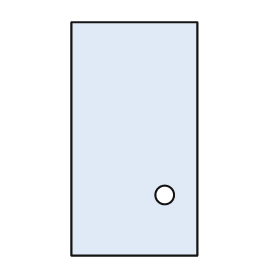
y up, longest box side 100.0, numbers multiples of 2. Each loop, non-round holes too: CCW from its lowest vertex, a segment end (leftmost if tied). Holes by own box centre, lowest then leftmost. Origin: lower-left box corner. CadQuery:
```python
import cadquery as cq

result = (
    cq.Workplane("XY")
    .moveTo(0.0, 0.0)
    .lineTo(54.0, 0.0)
    .lineTo(54.0, 100.0)
    .lineTo(0.0, 100.0)
    .close()
    .moveTo(40.0, 26.0)
    .circle(4.0)
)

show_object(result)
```